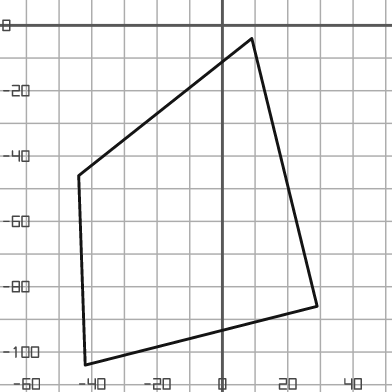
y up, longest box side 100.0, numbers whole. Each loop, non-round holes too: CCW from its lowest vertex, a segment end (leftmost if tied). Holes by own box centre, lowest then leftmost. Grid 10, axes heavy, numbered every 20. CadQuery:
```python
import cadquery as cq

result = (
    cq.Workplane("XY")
    .moveTo(-42.0, -104.0)
    .lineTo(29.0, -86.0)
    .lineTo(9.0, -4.0)
    .lineTo(-44.0, -46.0)
    .close()
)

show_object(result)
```